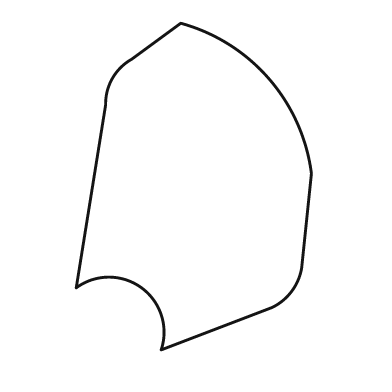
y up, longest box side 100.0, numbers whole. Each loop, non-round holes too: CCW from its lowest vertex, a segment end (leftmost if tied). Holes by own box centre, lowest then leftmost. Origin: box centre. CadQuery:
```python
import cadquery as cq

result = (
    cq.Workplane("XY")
    .moveTo(-10.0, -50.0)
    .lineTo(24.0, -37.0)
    .threePointArc((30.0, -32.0), (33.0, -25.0))
    .lineTo(36.0, 4.0)
    .threePointArc((23.0, 33.0), (-4.0, 50.0))
    .lineTo(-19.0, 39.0)
    .threePointArc((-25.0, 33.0), (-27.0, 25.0))
    .lineTo(-36.0, -31.0)
    .threePointArc((-16.0, -31.0), (-10.0, -50.0))
    .close()
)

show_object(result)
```